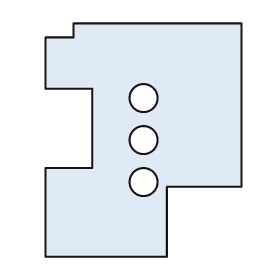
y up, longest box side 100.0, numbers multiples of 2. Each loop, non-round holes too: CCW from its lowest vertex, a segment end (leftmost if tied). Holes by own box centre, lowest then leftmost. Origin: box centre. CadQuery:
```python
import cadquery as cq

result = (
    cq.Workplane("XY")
    .moveTo(-42.0, -50.0)
    .lineTo(10.0, -50.0)
    .lineTo(10.0, -20.0)
    .lineTo(42.0, -20.0)
    .lineTo(42.0, 50.0)
    .lineTo(-30.0, 50.0)
    .lineTo(-30.0, 44.0)
    .lineTo(-42.0, 44.0)
    .lineTo(-42.0, 22.0)
    .lineTo(-22.0, 22.0)
    .lineTo(-22.0, -12.0)
    .lineTo(-42.0, -12.0)
    .close()
    .moveTo(0.0, -18.0)
    .circle(6.0)
    .moveTo(0.0, 0.0)
    .circle(6.0)
    .moveTo(0.0, 18.0)
    .circle(6.0)
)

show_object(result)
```